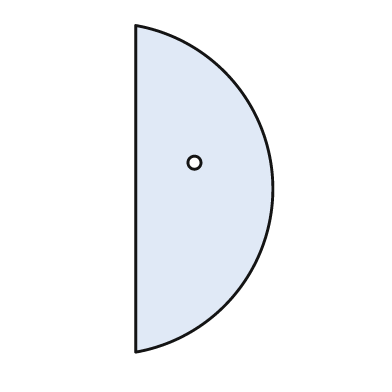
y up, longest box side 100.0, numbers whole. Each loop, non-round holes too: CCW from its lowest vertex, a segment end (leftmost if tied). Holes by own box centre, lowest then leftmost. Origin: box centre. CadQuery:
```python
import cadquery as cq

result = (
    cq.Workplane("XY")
    .moveTo(-21.0, -50.0)
    .threePointArc((21.0, 0.0), (-21.0, 50.0))
    .close()
    .moveTo(-3.0, 8.0)
    .circle(2.0)
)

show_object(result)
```